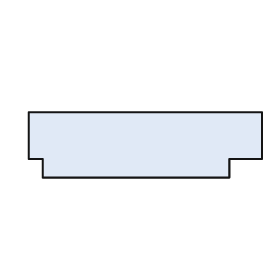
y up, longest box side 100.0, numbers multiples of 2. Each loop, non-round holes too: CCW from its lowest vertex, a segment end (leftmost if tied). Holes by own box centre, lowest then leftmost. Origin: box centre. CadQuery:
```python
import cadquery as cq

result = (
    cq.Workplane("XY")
    .moveTo(-44.0, -14.0)
    .lineTo(36.0, -14.0)
    .lineTo(36.0, -6.0)
    .lineTo(50.0, -6.0)
    .lineTo(50.0, 14.0)
    .lineTo(-50.0, 14.0)
    .lineTo(-50.0, -6.0)
    .lineTo(-44.0, -6.0)
    .close()
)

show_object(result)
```